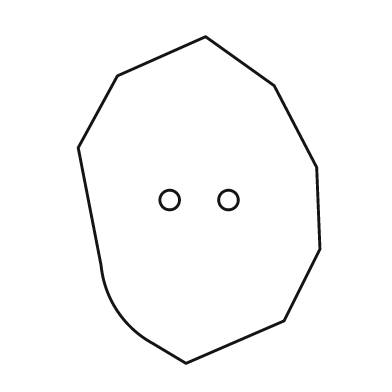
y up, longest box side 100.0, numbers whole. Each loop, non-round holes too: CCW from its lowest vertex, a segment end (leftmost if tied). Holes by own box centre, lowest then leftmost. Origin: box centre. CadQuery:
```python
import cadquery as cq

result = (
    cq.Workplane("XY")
    .moveTo(-4.0, -50.0)
    .lineTo(26.0, -37.0)
    .lineTo(37.0, -15.0)
    .lineTo(36.0, 10.0)
    .lineTo(23.0, 35.0)
    .lineTo(2.0, 50.0)
    .lineTo(-25.0, 38.0)
    .lineTo(-37.0, 16.0)
    .lineTo(-30.0, -20.0)
    .threePointArc((-25.0, -34.0), (-14.0, -44.0))
    .close()
    .moveTo(-9.0, 0.0)
    .circle(3.0)
    .moveTo(9.0, 0.0)
    .circle(3.0)
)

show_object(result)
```